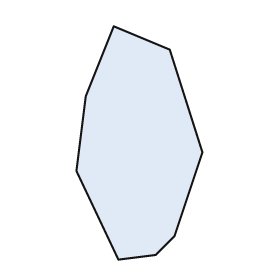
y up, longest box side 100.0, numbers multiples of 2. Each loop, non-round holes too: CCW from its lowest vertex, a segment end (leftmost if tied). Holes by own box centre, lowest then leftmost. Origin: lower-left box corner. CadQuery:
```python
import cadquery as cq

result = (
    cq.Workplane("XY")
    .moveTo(18.0, 0.0)
    .lineTo(34.0, 2.0)
    .lineTo(42.0, 10.0)
    .lineTo(54.0, 46.0)
    .lineTo(40.0, 90.0)
    .lineTo(16.0, 100.0)
    .lineTo(4.0, 70.0)
    .lineTo(0.0, 38.0)
    .close()
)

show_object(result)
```